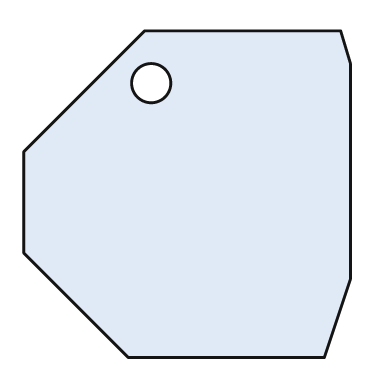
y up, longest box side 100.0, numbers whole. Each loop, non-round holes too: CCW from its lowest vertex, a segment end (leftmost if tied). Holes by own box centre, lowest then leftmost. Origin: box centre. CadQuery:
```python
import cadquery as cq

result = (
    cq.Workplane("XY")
    .moveTo(-18.0, -50.0)
    .lineTo(42.0, -50.0)
    .lineTo(50.0, -26.0)
    .lineTo(50.0, 40.0)
    .lineTo(47.0, 50.0)
    .lineTo(-13.0, 50.0)
    .lineTo(-50.0, 13.0)
    .lineTo(-50.0, -18.0)
    .close()
    .moveTo(-11.0, 34.0)
    .circle(6.0)
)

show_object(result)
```